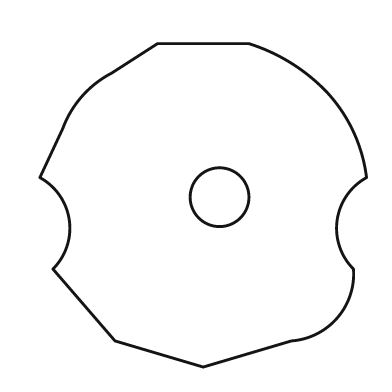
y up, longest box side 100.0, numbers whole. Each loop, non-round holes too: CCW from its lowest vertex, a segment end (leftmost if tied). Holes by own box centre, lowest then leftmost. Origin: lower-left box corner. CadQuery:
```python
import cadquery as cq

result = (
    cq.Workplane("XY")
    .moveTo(50.0, 0.0)
    .lineTo(77.0, 8.0)
    .threePointArc((91.0, 15.0), (96.0, 30.0))
    .threePointArc((91.0, 45.0), (100.0, 58.0))
    .threePointArc((96.0, 72.0), (88.0, 84.0))
    .threePointArc((77.0, 93.0), (64.0, 99.0))
    .lineTo(36.0, 99.0)
    .lineTo(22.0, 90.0)
    .threePointArc((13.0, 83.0), (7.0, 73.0))
    .lineTo(0.0, 58.0)
    .threePointArc((9.0, 45.0), (4.0, 30.0))
    .lineTo(23.0, 8.0)
    .close()
    .moveTo(55.0, 52.0)
    .circle(9.0)
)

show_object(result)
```